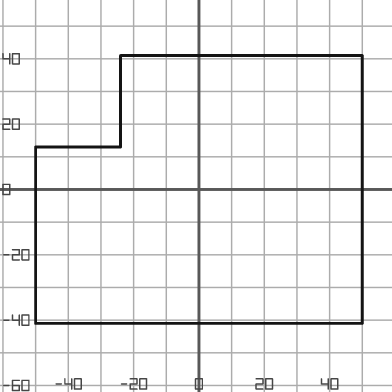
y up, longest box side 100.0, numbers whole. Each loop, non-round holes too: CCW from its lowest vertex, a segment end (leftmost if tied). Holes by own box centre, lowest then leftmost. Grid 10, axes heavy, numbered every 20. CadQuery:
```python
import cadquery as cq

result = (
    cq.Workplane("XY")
    .moveTo(-50.0, -41.0)
    .lineTo(50.0, -41.0)
    .lineTo(50.0, 41.0)
    .lineTo(-24.0, 41.0)
    .lineTo(-24.0, 13.0)
    .lineTo(-50.0, 13.0)
    .close()
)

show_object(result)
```